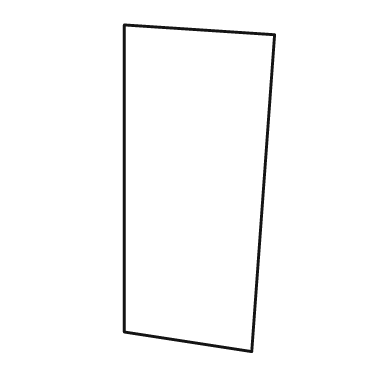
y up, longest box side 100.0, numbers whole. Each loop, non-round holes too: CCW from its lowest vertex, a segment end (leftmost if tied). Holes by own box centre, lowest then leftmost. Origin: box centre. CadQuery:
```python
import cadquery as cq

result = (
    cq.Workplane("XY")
    .moveTo(16.0, -50.0)
    .lineTo(23.0, 47.0)
    .lineTo(-23.0, 50.0)
    .lineTo(-23.0, -44.0)
    .close()
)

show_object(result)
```